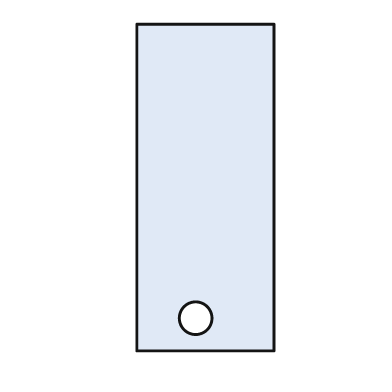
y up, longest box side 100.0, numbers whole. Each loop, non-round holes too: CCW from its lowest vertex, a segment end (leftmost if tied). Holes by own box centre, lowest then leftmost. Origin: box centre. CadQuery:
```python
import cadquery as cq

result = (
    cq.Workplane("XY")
    .moveTo(-21.0, -50.0)
    .lineTo(21.0, -50.0)
    .lineTo(21.0, 50.0)
    .lineTo(-21.0, 50.0)
    .close()
    .moveTo(-3.0, -40.0)
    .circle(5.0)
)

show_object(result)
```